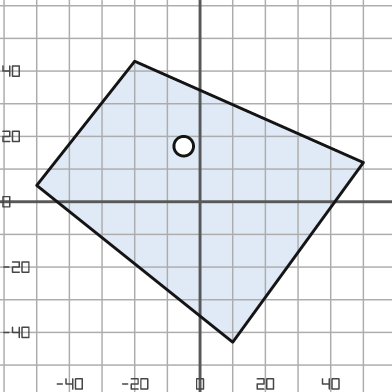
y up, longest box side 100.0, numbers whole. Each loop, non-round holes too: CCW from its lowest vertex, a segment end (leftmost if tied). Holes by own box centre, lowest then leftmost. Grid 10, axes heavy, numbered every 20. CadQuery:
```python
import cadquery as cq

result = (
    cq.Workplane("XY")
    .moveTo(10.0, -43.0)
    .lineTo(50.0, 12.0)
    .lineTo(-20.0, 43.0)
    .lineTo(-50.0, 5.0)
    .close()
    .moveTo(-5.0, 17.0)
    .circle(3.0)
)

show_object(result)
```